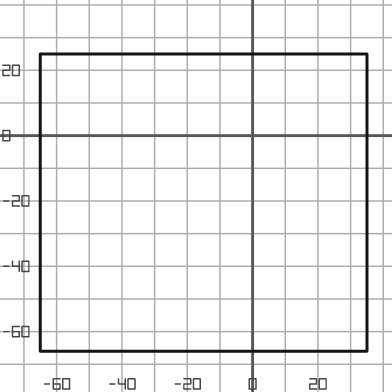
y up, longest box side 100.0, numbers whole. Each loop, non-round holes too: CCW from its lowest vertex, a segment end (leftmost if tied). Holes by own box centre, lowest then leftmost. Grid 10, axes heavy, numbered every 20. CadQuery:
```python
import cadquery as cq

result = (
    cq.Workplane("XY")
    .moveTo(-65.0, -66.0)
    .lineTo(35.0, -66.0)
    .lineTo(35.0, 25.0)
    .lineTo(-65.0, 25.0)
    .close()
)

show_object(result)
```